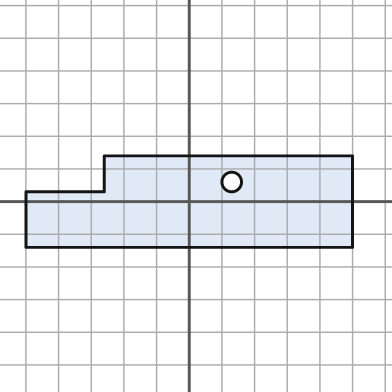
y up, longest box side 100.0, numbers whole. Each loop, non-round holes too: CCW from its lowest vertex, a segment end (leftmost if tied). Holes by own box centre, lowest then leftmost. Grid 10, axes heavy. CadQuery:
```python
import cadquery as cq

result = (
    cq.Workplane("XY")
    .moveTo(-50.0, -14.0)
    .lineTo(50.0, -14.0)
    .lineTo(50.0, 14.0)
    .lineTo(-26.0, 14.0)
    .lineTo(-26.0, 3.0)
    .lineTo(-50.0, 3.0)
    .close()
    .moveTo(13.0, 6.0)
    .circle(3.0)
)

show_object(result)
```